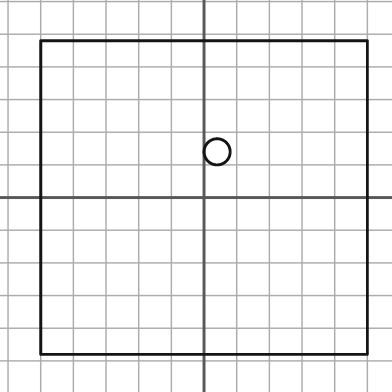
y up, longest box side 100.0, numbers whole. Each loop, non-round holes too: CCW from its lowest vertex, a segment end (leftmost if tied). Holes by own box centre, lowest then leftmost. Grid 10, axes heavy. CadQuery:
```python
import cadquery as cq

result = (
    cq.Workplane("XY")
    .moveTo(-50.0, -48.0)
    .lineTo(50.0, -48.0)
    .lineTo(50.0, 48.0)
    .lineTo(-50.0, 48.0)
    .close()
    .moveTo(4.0, 14.0)
    .circle(4.0)
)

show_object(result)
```